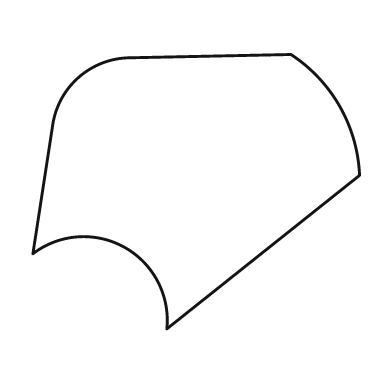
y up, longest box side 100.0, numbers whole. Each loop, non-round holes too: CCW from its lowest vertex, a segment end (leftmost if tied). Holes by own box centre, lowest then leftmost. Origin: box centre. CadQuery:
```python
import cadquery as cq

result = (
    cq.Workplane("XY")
    .moveTo(-9.0, -42.0)
    .lineTo(50.0, 5.0)
    .threePointArc((44.0, 26.0), (29.0, 42.0))
    .lineTo(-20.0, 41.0)
    .threePointArc((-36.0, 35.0), (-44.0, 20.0))
    .lineTo(-50.0, -19.0)
    .threePointArc((-22.0, -17.0), (-9.0, -42.0))
    .close()
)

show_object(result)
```